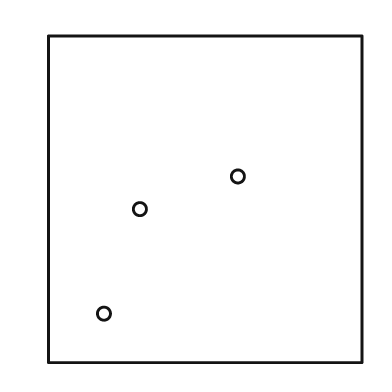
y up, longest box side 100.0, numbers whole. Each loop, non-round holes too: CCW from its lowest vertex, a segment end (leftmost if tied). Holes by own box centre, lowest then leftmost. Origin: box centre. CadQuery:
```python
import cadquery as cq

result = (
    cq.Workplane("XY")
    .moveTo(-48.0, -50.0)
    .lineTo(48.0, -50.0)
    .lineTo(48.0, 50.0)
    .lineTo(-48.0, 50.0)
    .close()
    .moveTo(-31.0, -35.0)
    .circle(2.0)
    .moveTo(-20.0, -3.0)
    .circle(2.0)
    .moveTo(10.0, 7.0)
    .circle(2.0)
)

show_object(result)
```